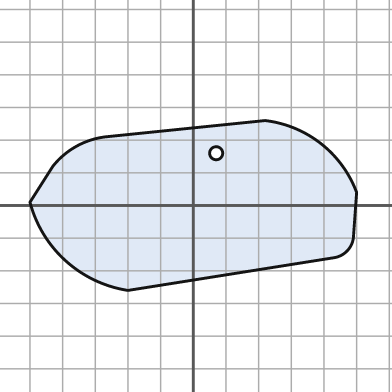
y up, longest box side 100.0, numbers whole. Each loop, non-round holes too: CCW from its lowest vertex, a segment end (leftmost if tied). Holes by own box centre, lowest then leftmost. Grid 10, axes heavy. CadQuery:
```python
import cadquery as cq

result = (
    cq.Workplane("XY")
    .moveTo(-20.0, -26.0)
    .lineTo(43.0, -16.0)
    .threePointArc((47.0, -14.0), (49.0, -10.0))
    .lineTo(50.0, 4.0)
    .threePointArc((39.0, 19.0), (22.0, 26.0))
    .lineTo(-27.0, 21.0)
    .threePointArc((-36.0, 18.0), (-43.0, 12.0))
    .lineTo(-50.0, 1.0)
    .threePointArc((-39.0, -17.0), (-20.0, -26.0))
    .close()
    .moveTo(7.0, 16.0)
    .circle(2.0)
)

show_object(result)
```